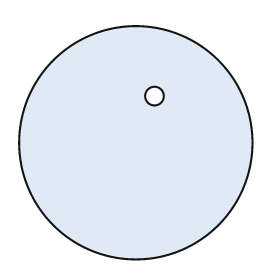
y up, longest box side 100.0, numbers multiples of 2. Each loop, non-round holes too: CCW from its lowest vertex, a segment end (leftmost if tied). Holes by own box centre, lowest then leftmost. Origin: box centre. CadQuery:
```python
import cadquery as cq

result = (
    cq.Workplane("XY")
    .moveTo(0.0, 0.0)
    .circle(50.0)
    .moveTo(8.0, 20.0)
    .circle(4.0)
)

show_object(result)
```